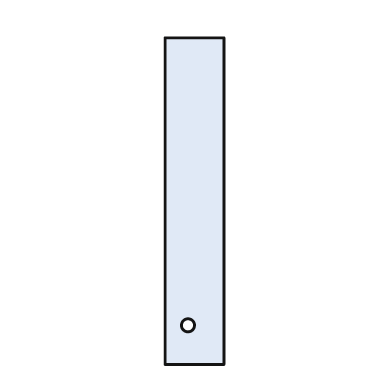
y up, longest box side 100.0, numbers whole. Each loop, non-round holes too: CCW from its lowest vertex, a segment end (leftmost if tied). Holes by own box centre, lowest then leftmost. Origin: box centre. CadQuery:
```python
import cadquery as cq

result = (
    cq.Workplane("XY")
    .moveTo(-9.0, -50.0)
    .lineTo(9.0, -50.0)
    .lineTo(9.0, 50.0)
    .lineTo(-9.0, 50.0)
    .close()
    .moveTo(-2.0, -38.0)
    .circle(2.0)
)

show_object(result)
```